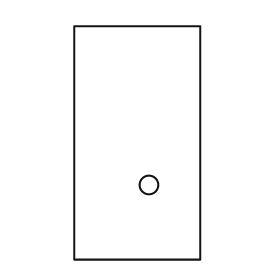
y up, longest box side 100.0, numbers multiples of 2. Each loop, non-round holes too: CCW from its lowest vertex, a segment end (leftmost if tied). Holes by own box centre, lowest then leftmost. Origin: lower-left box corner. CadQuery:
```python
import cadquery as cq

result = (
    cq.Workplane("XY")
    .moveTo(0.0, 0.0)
    .lineTo(54.0, 0.0)
    .lineTo(54.0, 100.0)
    .lineTo(0.0, 100.0)
    .close()
    .moveTo(32.0, 32.0)
    .circle(4.0)
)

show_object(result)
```